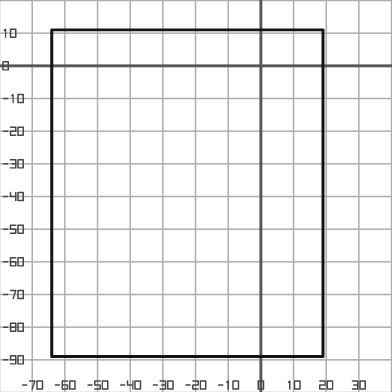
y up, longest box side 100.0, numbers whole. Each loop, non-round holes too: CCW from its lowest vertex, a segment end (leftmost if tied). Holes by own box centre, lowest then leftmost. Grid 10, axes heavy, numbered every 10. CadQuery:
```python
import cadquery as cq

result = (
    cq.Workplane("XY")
    .moveTo(-64.0, -89.0)
    .lineTo(19.0, -89.0)
    .lineTo(19.0, 11.0)
    .lineTo(-64.0, 11.0)
    .close()
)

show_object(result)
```